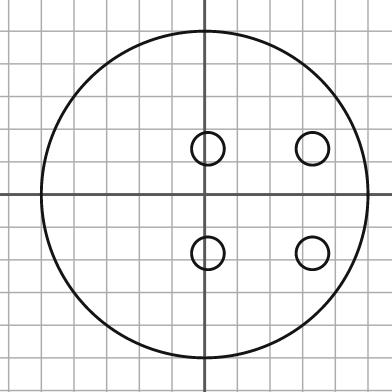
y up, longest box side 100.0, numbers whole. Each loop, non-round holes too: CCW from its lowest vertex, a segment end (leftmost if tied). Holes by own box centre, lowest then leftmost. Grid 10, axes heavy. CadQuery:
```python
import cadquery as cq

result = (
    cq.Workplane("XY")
    .moveTo(0.0, 0.0)
    .circle(50.0)
    .moveTo(1.0, -18.0)
    .circle(5.0)
    .moveTo(33.0, -18.0)
    .circle(5.0)
    .moveTo(1.0, 14.0)
    .circle(5.0)
    .moveTo(33.0, 14.0)
    .circle(5.0)
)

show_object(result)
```